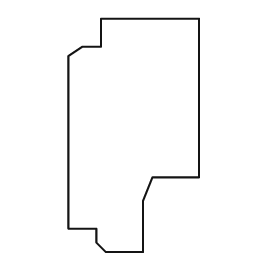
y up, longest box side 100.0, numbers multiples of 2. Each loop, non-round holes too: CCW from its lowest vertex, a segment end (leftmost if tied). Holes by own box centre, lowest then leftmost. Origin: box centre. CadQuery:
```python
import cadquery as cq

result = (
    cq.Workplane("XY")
    .moveTo(-12.0, -50.0)
    .lineTo(4.0, -50.0)
    .lineTo(4.0, -28.0)
    .lineTo(8.0, -18.0)
    .lineTo(28.0, -18.0)
    .lineTo(28.0, 50.0)
    .lineTo(-14.0, 50.0)
    .lineTo(-14.0, 38.0)
    .lineTo(-22.0, 38.0)
    .lineTo(-28.0, 34.0)
    .lineTo(-28.0, -40.0)
    .lineTo(-16.0, -40.0)
    .lineTo(-16.0, -46.0)
    .close()
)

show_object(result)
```